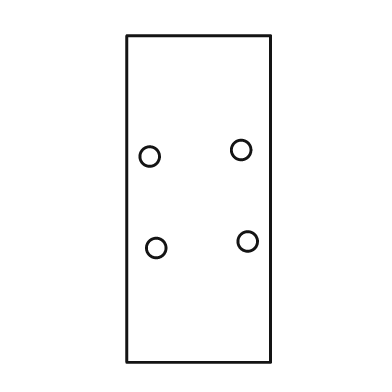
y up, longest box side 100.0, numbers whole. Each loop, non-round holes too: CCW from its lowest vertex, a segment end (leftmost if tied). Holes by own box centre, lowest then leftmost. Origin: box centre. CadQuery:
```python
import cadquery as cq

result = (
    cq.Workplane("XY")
    .moveTo(-22.0, -50.0)
    .lineTo(22.0, -50.0)
    .lineTo(22.0, 50.0)
    .lineTo(-22.0, 50.0)
    .close()
    .moveTo(-13.0, -15.0)
    .circle(3.0)
    .moveTo(15.0, -13.0)
    .circle(3.0)
    .moveTo(-15.0, 13.0)
    .circle(3.0)
    .moveTo(13.0, 15.0)
    .circle(3.0)
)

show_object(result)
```